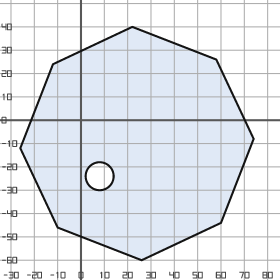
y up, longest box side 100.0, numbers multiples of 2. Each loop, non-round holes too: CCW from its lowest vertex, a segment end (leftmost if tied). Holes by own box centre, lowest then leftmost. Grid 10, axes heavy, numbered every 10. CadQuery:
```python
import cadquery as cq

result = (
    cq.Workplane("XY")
    .moveTo(26.0, -60.0)
    .lineTo(60.0, -44.0)
    .lineTo(74.0, -8.0)
    .lineTo(58.0, 26.0)
    .lineTo(22.0, 40.0)
    .lineTo(-12.0, 24.0)
    .lineTo(-26.0, -12.0)
    .lineTo(-10.0, -46.0)
    .close()
    .moveTo(8.0, -24.0)
    .circle(6.0)
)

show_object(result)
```